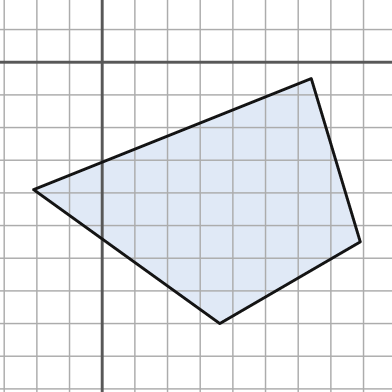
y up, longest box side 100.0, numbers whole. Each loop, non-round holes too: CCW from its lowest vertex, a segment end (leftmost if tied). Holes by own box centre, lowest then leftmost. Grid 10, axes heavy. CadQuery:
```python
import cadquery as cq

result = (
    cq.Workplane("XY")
    .moveTo(36.0, -80.0)
    .lineTo(79.0, -55.0)
    .lineTo(64.0, -5.0)
    .lineTo(-21.0, -39.0)
    .close()
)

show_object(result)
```